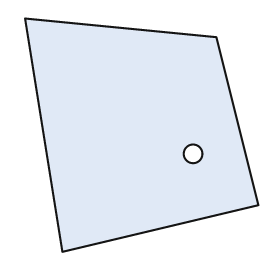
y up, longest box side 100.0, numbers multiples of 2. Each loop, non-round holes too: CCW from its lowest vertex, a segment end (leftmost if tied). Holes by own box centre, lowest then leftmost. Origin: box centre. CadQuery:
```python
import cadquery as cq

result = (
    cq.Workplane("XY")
    .moveTo(-34.0, -50.0)
    .lineTo(50.0, -30.0)
    .lineTo(32.0, 42.0)
    .lineTo(-50.0, 50.0)
    .close()
    .moveTo(22.0, -8.0)
    .circle(4.0)
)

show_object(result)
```